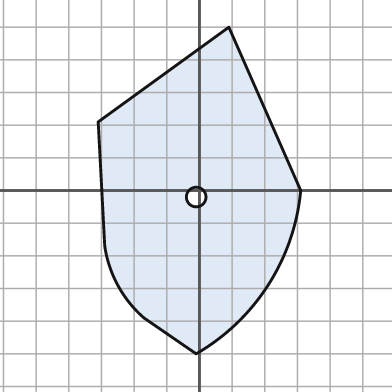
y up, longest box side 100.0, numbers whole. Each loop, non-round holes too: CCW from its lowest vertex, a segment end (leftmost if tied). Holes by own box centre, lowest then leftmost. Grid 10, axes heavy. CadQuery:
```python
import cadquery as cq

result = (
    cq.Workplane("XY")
    .moveTo(-1.0, -50.0)
    .threePointArc((21.0, -29.0), (31.0, 0.0))
    .lineTo(9.0, 50.0)
    .lineTo(-31.0, 21.0)
    .lineTo(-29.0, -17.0)
    .threePointArc((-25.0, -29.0), (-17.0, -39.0))
    .close()
    .moveTo(-1.0, -2.0)
    .circle(3.0)
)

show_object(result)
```